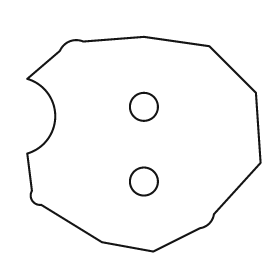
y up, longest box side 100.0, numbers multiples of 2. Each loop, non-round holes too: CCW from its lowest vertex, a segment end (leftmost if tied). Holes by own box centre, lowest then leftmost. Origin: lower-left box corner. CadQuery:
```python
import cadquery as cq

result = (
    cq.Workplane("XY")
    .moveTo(54.0, 0.0)
    .lineTo(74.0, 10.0)
    .threePointArc((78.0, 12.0), (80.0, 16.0))
    .lineTo(100.0, 38.0)
    .lineTo(98.0, 68.0)
    .lineTo(78.0, 88.0)
    .lineTo(50.0, 92.0)
    .lineTo(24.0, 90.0)
    .threePointArc((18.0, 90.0), (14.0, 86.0))
    .lineTo(0.0, 74.0)
    .threePointArc((12.0, 58.0), (0.0, 42.0))
    .lineTo(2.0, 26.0)
    .threePointArc((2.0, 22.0), (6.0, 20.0))
    .lineTo(32.0, 4.0)
    .close()
    .moveTo(50.0, 30.0)
    .circle(6.0)
    .moveTo(50.0, 62.0)
    .circle(6.0)
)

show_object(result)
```